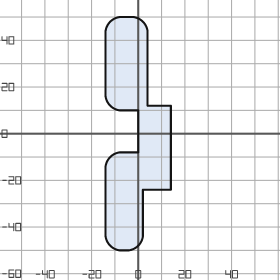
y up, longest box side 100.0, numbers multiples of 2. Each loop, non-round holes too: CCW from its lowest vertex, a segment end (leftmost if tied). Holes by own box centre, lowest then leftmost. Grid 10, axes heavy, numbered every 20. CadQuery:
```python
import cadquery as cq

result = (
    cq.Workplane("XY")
    .moveTo(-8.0, -50.0)
    .lineTo(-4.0, -50.0)
    .threePointArc((0.0, -48.0), (2.0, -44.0))
    .lineTo(2.0, -24.0)
    .lineTo(14.0, -24.0)
    .lineTo(14.0, 12.0)
    .lineTo(4.0, 12.0)
    .lineTo(4.0, 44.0)
    .threePointArc((2.0, 48.0), (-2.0, 50.0))
    .lineTo(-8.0, 50.0)
    .threePointArc((-12.0, 48.0), (-14.0, 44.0))
    .lineTo(-14.0, 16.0)
    .threePointArc((-12.0, 12.0), (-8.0, 10.0))
    .lineTo(0.0, 10.0)
    .lineTo(0.0, -8.0)
    .lineTo(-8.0, -8.0)
    .threePointArc((-12.0, -10.0), (-14.0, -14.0))
    .lineTo(-14.0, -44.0)
    .threePointArc((-12.0, -48.0), (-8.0, -50.0))
    .close()
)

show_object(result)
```